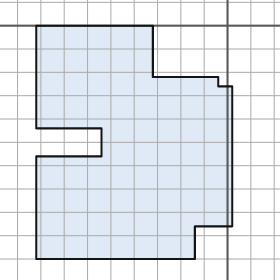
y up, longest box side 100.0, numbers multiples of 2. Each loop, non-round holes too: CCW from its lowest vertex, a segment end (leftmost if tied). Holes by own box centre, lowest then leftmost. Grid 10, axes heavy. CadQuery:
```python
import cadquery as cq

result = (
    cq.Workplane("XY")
    .moveTo(-82.0, -100.0)
    .lineTo(-14.0, -100.0)
    .lineTo(-14.0, -86.0)
    .lineTo(2.0, -86.0)
    .lineTo(2.0, -26.0)
    .lineTo(-4.0, -26.0)
    .lineTo(-4.0, -22.0)
    .lineTo(-32.0, -22.0)
    .lineTo(-32.0, 0.0)
    .lineTo(-82.0, 0.0)
    .lineTo(-82.0, -44.0)
    .lineTo(-54.0, -44.0)
    .lineTo(-54.0, -56.0)
    .lineTo(-82.0, -56.0)
    .close()
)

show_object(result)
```